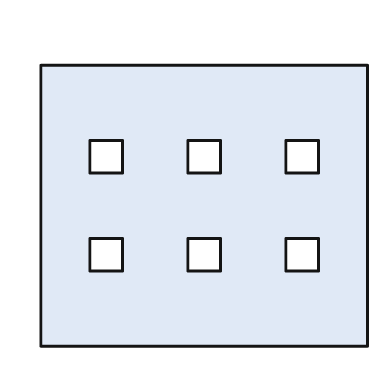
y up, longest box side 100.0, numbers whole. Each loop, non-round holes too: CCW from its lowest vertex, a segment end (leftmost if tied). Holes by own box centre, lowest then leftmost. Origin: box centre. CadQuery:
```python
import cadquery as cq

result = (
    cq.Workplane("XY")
    .moveTo(-50.0, -43.0)
    .lineTo(50.0, -43.0)
    .lineTo(50.0, 43.0)
    .lineTo(-50.0, 43.0)
    .close()
    .moveTo(-35.0, -20.0)
    .lineTo(-25.0, -20.0)
    .lineTo(-25.0, -10.0)
    .lineTo(-35.0, -10.0)
    .close()
    .moveTo(-5.0, -20.0)
    .lineTo(5.0, -20.0)
    .lineTo(5.0, -10.0)
    .lineTo(-5.0, -10.0)
    .close()
    .moveTo(25.0, -20.0)
    .lineTo(35.0, -20.0)
    .lineTo(35.0, -10.0)
    .lineTo(25.0, -10.0)
    .close()
    .moveTo(-35.0, 10.0)
    .lineTo(-25.0, 10.0)
    .lineTo(-25.0, 20.0)
    .lineTo(-35.0, 20.0)
    .close()
    .moveTo(-5.0, 10.0)
    .lineTo(5.0, 10.0)
    .lineTo(5.0, 20.0)
    .lineTo(-5.0, 20.0)
    .close()
    .moveTo(25.0, 10.0)
    .lineTo(35.0, 10.0)
    .lineTo(35.0, 20.0)
    .lineTo(25.0, 20.0)
    .close()
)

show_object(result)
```